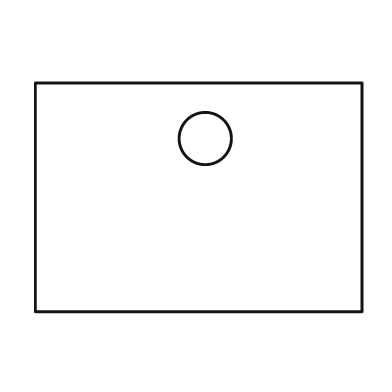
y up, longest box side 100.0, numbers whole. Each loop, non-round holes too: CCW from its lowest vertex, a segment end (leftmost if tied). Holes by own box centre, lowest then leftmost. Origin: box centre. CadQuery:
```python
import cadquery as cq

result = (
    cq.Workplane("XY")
    .moveTo(-50.0, -35.0)
    .lineTo(50.0, -35.0)
    .lineTo(50.0, 35.0)
    .lineTo(-50.0, 35.0)
    .close()
    .moveTo(2.0, 18.0)
    .circle(8.0)
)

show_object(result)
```